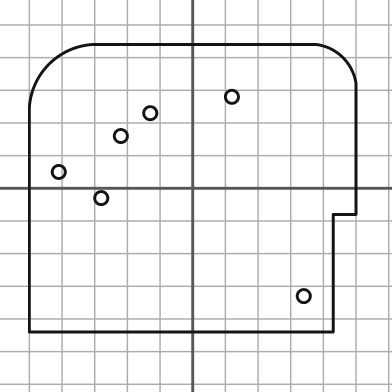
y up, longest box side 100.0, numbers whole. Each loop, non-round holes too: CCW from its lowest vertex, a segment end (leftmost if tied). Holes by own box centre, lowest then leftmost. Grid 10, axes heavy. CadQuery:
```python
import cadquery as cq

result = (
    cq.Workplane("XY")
    .moveTo(-50.0, -44.0)
    .lineTo(43.0, -44.0)
    .lineTo(43.0, -8.0)
    .lineTo(50.0, -8.0)
    .lineTo(50.0, 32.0)
    .threePointArc((46.0, 40.0), (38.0, 44.0))
    .lineTo(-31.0, 44.0)
    .threePointArc((-44.0, 38.0), (-50.0, 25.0))
    .close()
    .moveTo(34.0, -33.0)
    .circle(2.0)
    .moveTo(-28.0, -3.0)
    .circle(2.0)
    .moveTo(-41.0, 5.0)
    .circle(2.0)
    .moveTo(-22.0, 16.0)
    .circle(2.0)
    .moveTo(-13.0, 23.0)
    .circle(2.0)
    .moveTo(12.0, 28.0)
    .circle(2.0)
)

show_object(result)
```